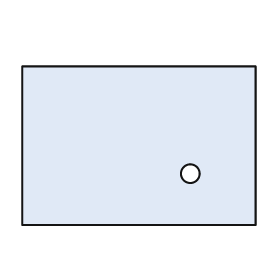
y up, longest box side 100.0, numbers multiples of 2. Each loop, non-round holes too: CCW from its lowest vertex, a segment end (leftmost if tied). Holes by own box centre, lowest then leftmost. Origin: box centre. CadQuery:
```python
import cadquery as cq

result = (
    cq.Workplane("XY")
    .moveTo(-50.0, -34.0)
    .lineTo(50.0, -34.0)
    .lineTo(50.0, 34.0)
    .lineTo(-50.0, 34.0)
    .close()
    .moveTo(22.0, -12.0)
    .circle(4.0)
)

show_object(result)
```